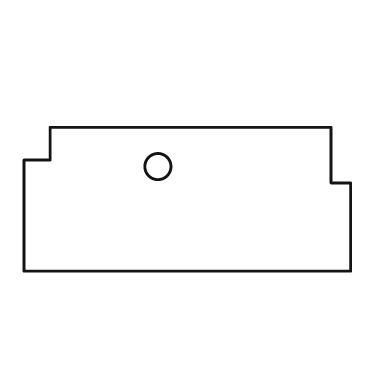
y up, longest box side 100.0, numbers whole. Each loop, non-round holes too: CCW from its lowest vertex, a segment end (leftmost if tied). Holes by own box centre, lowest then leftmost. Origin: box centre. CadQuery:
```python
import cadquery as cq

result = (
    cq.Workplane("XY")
    .moveTo(-50.0, -22.0)
    .lineTo(50.0, -22.0)
    .lineTo(50.0, 5.0)
    .lineTo(44.0, 5.0)
    .lineTo(44.0, 22.0)
    .lineTo(-42.0, 22.0)
    .lineTo(-42.0, 12.0)
    .lineTo(-50.0, 12.0)
    .close()
    .moveTo(-9.0, 10.0)
    .circle(4.0)
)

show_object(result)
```